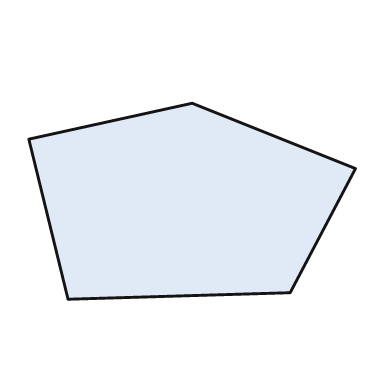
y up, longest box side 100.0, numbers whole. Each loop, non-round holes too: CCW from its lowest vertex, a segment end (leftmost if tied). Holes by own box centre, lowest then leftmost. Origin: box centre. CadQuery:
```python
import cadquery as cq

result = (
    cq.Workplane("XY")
    .moveTo(-38.0, -30.0)
    .lineTo(30.0, -28.0)
    .lineTo(50.0, 10.0)
    .lineTo(0.0, 30.0)
    .lineTo(-50.0, 19.0)
    .close()
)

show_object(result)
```